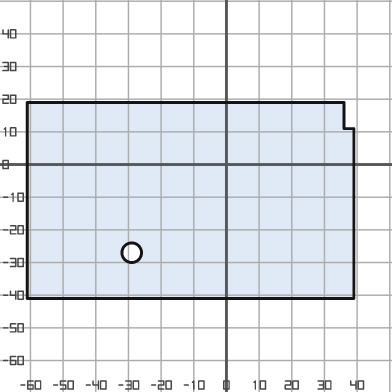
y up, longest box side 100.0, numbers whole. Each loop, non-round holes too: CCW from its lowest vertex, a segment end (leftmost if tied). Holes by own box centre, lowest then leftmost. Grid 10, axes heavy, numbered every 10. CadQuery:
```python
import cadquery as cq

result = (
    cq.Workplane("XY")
    .moveTo(-61.0, -41.0)
    .lineTo(39.0, -41.0)
    .lineTo(39.0, 11.0)
    .lineTo(36.0, 11.0)
    .lineTo(36.0, 19.0)
    .lineTo(-61.0, 19.0)
    .close()
    .moveTo(-29.0, -27.0)
    .circle(3.0)
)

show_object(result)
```